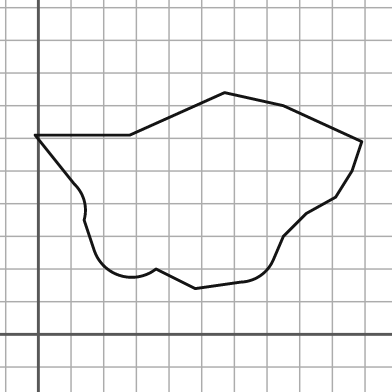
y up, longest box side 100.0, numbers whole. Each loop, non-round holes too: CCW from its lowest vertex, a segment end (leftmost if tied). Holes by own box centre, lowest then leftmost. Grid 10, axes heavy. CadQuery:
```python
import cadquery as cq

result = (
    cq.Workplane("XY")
    .moveTo(48.0, 14.0)
    .lineTo(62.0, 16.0)
    .threePointArc((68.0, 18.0), (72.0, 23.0))
    .lineTo(75.0, 30.0)
    .lineTo(82.0, 37.0)
    .lineTo(91.0, 42.0)
    .lineTo(96.0, 50.0)
    .lineTo(99.0, 59.0)
    .lineTo(75.0, 70.0)
    .lineTo(57.0, 74.0)
    .lineTo(28.0, 61.0)
    .lineTo(-1.0, 61.0)
    .lineTo(11.0, 46.0)
    .threePointArc((14.0, 41.0), (14.0, 35.0))
    .lineTo(17.0, 26.0)
    .threePointArc((25.0, 18.0), (36.0, 20.0))
    .close()
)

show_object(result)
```